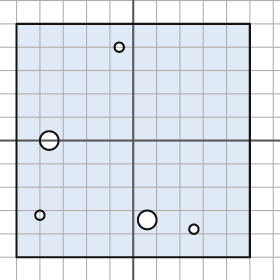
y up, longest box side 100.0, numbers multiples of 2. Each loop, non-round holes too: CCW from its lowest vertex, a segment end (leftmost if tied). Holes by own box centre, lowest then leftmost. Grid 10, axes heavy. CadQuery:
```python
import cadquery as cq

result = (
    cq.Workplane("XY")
    .moveTo(-50.0, -50.0)
    .lineTo(50.0, -50.0)
    .lineTo(50.0, 50.0)
    .lineTo(-50.0, 50.0)
    .close()
    .moveTo(26.0, -38.0)
    .circle(2.0)
    .moveTo(6.0, -34.0)
    .circle(4.0)
    .moveTo(-40.0, -32.0)
    .circle(2.0)
    .moveTo(-36.0, 0.0)
    .circle(4.0)
    .moveTo(-6.0, 40.0)
    .circle(2.0)
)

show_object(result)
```